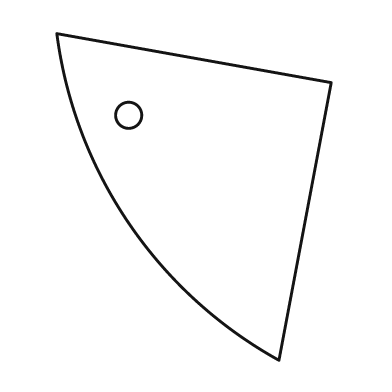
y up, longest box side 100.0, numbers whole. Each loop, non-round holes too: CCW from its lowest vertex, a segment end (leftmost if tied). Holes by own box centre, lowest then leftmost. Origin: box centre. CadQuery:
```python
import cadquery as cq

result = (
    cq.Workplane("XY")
    .moveTo(26.0, -50.0)
    .lineTo(42.0, 35.0)
    .lineTo(-42.0, 50.0)
    .threePointArc((-20.0, -8.0), (26.0, -50.0))
    .close()
    .moveTo(-20.0, 25.0)
    .circle(4.0)
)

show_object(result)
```